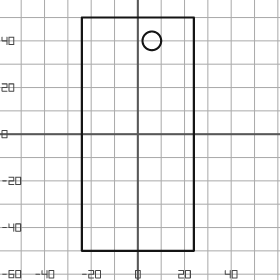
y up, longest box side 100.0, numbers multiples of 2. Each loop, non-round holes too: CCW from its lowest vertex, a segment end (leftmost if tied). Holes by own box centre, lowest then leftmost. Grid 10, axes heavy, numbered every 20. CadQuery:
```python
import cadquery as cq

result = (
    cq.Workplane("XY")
    .moveTo(-24.0, -50.0)
    .lineTo(24.0, -50.0)
    .lineTo(24.0, 50.0)
    .lineTo(-24.0, 50.0)
    .close()
    .moveTo(6.0, 40.0)
    .circle(4.0)
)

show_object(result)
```